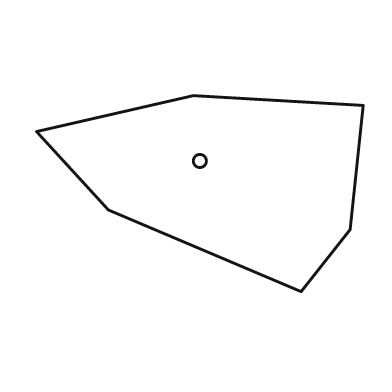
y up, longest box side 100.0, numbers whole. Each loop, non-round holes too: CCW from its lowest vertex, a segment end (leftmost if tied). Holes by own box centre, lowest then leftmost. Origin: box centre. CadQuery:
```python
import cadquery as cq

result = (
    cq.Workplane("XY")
    .moveTo(31.0, -30.0)
    .lineTo(46.0, -11.0)
    .lineTo(50.0, 27.0)
    .lineTo(-2.0, 30.0)
    .lineTo(-50.0, 19.0)
    .lineTo(-28.0, -5.0)
    .close()
    .moveTo(0.0, 10.0)
    .circle(2.0)
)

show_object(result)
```